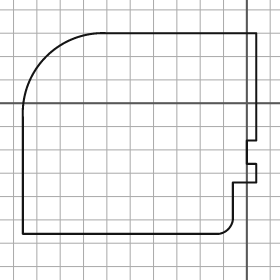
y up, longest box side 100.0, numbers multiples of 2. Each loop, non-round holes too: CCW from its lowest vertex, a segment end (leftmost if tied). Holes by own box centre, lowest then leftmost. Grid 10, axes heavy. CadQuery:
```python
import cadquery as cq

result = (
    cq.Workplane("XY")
    .moveTo(-96.0, -56.0)
    .lineTo(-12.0, -56.0)
    .threePointArc((-8.0, -54.0), (-6.0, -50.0))
    .lineTo(-6.0, -34.0)
    .lineTo(4.0, -34.0)
    .lineTo(4.0, -26.0)
    .lineTo(0.0, -26.0)
    .lineTo(0.0, -16.0)
    .lineTo(4.0, -16.0)
    .lineTo(4.0, 30.0)
    .lineTo(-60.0, 30.0)
    .threePointArc((-86.0, 20.0), (-96.0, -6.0))
    .close()
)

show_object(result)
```